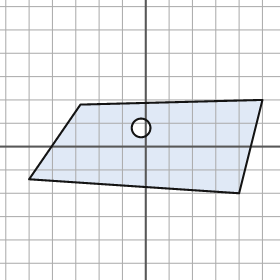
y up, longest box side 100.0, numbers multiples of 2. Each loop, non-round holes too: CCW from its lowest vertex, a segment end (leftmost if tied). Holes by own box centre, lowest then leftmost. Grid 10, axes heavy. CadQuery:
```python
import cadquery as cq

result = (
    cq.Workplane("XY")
    .moveTo(40.0, -20.0)
    .lineTo(50.0, 20.0)
    .lineTo(-28.0, 18.0)
    .lineTo(-50.0, -14.0)
    .close()
    .moveTo(-2.0, 8.0)
    .circle(4.0)
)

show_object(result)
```